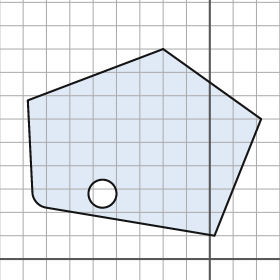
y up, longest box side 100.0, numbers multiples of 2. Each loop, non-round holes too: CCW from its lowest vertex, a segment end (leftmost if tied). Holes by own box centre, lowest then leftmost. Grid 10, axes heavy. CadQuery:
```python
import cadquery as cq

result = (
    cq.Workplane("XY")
    .moveTo(2.0, 10.0)
    .lineTo(22.0, 60.0)
    .lineTo(-20.0, 90.0)
    .lineTo(-78.0, 68.0)
    .lineTo(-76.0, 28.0)
    .threePointArc((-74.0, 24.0), (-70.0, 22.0))
    .close()
    .moveTo(-46.0, 28.0)
    .circle(6.0)
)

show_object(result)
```